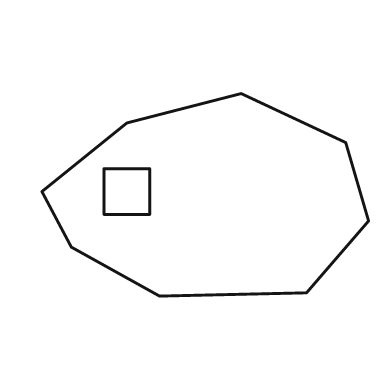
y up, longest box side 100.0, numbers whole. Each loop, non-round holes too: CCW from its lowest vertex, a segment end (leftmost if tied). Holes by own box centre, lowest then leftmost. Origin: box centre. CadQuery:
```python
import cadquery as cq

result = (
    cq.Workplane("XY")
    .moveTo(-14.0, -31.0)
    .lineTo(31.0, -30.0)
    .lineTo(50.0, -8.0)
    .lineTo(43.0, 16.0)
    .lineTo(11.0, 31.0)
    .lineTo(-24.0, 22.0)
    .lineTo(-50.0, 1.0)
    .lineTo(-41.0, -16.0)
    .close()
    .moveTo(-31.0, -6.0)
    .lineTo(-17.0, -6.0)
    .lineTo(-17.0, 8.0)
    .lineTo(-31.0, 8.0)
    .close()
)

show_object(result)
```